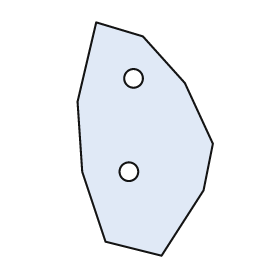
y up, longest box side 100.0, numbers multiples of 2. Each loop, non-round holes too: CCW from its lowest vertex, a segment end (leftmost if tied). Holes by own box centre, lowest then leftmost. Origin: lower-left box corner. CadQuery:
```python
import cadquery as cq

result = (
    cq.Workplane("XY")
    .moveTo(36.0, 0.0)
    .lineTo(54.0, 28.0)
    .lineTo(58.0, 48.0)
    .lineTo(46.0, 74.0)
    .lineTo(28.0, 94.0)
    .lineTo(8.0, 100.0)
    .lineTo(0.0, 66.0)
    .lineTo(2.0, 36.0)
    .lineTo(12.0, 6.0)
    .close()
    .moveTo(22.0, 36.0)
    .circle(4.0)
    .moveTo(24.0, 76.0)
    .circle(4.0)
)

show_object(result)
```